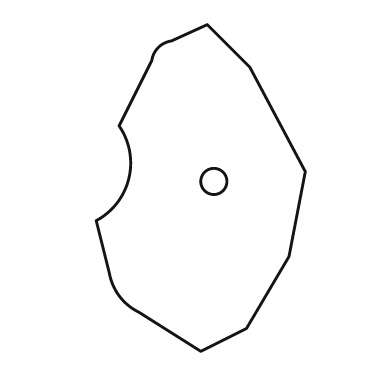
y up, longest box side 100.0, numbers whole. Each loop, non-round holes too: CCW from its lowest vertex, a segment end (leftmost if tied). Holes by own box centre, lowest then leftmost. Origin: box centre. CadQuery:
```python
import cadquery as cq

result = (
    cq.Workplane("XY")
    .moveTo(0.0, -50.0)
    .lineTo(14.0, -43.0)
    .lineTo(27.0, -21.0)
    .lineTo(32.0, 5.0)
    .lineTo(15.0, 37.0)
    .lineTo(2.0, 50.0)
    .lineTo(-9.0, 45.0)
    .threePointArc((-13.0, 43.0), (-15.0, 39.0))
    .lineTo(-25.0, 19.0)
    .threePointArc((-22.0, 3.0), (-32.0, -10.0))
    .lineTo(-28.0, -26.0)
    .threePointArc((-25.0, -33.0), (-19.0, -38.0))
    .close()
    .moveTo(4.0, 2.0)
    .circle(4.0)
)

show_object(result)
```